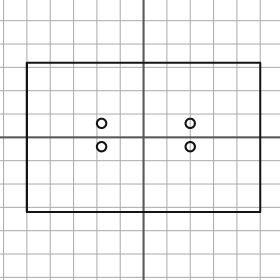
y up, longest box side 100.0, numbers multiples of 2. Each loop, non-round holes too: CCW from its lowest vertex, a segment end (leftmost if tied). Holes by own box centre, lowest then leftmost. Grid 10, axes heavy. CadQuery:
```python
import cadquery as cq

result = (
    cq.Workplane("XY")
    .moveTo(-50.0, -32.0)
    .lineTo(50.0, -32.0)
    .lineTo(50.0, 32.0)
    .lineTo(-50.0, 32.0)
    .close()
    .moveTo(-18.0, -4.0)
    .circle(2.0)
    .moveTo(20.0, -4.0)
    .circle(2.0)
    .moveTo(-18.0, 6.0)
    .circle(2.0)
    .moveTo(20.0, 6.0)
    .circle(2.0)
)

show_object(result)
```